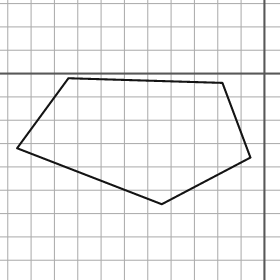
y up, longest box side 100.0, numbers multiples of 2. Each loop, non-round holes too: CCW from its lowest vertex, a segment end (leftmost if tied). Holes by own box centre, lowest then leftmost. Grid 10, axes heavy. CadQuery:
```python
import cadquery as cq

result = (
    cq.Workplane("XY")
    .moveTo(-44.0, -56.0)
    .lineTo(-6.0, -36.0)
    .lineTo(-18.0, -4.0)
    .lineTo(-84.0, -2.0)
    .lineTo(-106.0, -32.0)
    .close()
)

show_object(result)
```